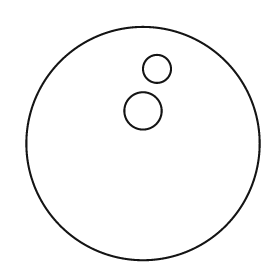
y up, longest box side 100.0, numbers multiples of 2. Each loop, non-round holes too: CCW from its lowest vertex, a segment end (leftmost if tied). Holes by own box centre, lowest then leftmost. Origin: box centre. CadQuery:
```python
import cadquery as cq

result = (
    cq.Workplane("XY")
    .moveTo(0.0, 0.0)
    .circle(50.0)
    .moveTo(0.0, 14.0)
    .circle(8.0)
    .moveTo(6.0, 32.0)
    .circle(6.0)
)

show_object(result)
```